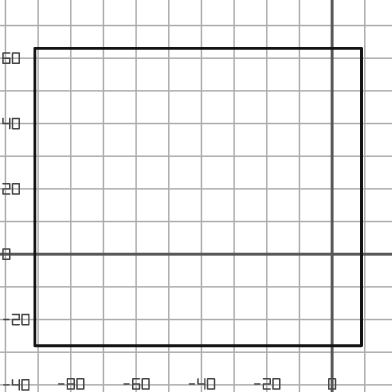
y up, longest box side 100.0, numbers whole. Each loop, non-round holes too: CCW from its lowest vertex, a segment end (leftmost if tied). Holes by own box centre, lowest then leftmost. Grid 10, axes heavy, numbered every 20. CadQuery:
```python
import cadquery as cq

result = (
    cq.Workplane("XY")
    .moveTo(-91.0, -28.0)
    .lineTo(9.0, -28.0)
    .lineTo(9.0, 63.0)
    .lineTo(-91.0, 63.0)
    .close()
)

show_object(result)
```